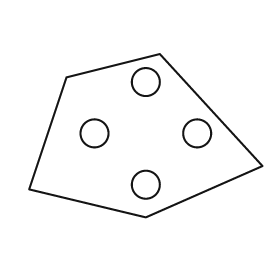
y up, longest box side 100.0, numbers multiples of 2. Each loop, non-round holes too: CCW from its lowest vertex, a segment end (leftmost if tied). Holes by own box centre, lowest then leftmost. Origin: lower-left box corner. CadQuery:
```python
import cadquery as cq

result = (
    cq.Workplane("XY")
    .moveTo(50.0, 0.0)
    .lineTo(100.0, 22.0)
    .lineTo(56.0, 70.0)
    .lineTo(16.0, 60.0)
    .lineTo(0.0, 12.0)
    .close()
    .moveTo(50.0, 14.0)
    .circle(6.0)
    .moveTo(28.0, 36.0)
    .circle(6.0)
    .moveTo(72.0, 36.0)
    .circle(6.0)
    .moveTo(50.0, 58.0)
    .circle(6.0)
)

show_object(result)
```